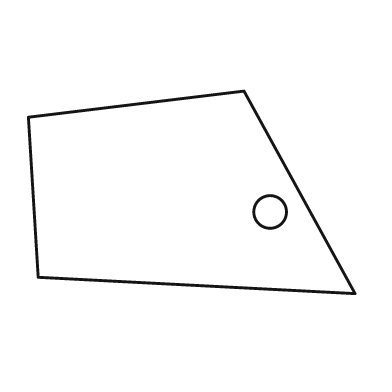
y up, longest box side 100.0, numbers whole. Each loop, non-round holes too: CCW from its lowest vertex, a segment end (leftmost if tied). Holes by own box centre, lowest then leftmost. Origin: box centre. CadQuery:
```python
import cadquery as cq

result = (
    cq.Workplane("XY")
    .moveTo(50.0, -31.0)
    .lineTo(16.0, 31.0)
    .lineTo(-50.0, 23.0)
    .lineTo(-47.0, -26.0)
    .close()
    .moveTo(24.0, -6.0)
    .circle(5.0)
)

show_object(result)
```